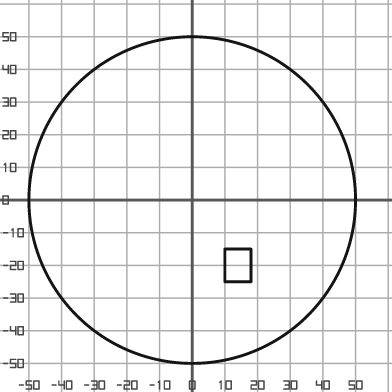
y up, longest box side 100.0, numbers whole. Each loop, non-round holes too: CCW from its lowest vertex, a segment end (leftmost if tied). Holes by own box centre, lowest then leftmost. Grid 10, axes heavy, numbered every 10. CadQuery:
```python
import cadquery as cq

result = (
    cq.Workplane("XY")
    .moveTo(0.0, 0.0)
    .circle(50.0)
    .moveTo(10.0, -25.0)
    .lineTo(18.0, -25.0)
    .lineTo(18.0, -15.0)
    .lineTo(10.0, -15.0)
    .close()
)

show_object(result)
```